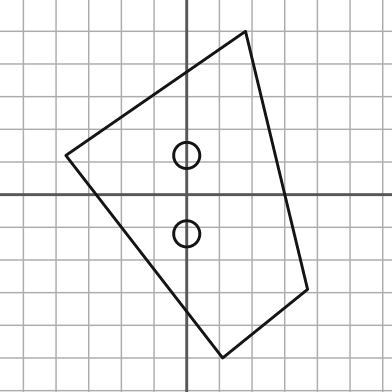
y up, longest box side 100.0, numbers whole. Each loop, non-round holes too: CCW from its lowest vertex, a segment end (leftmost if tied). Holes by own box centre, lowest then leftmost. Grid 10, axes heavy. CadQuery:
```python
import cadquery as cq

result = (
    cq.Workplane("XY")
    .moveTo(11.0, -50.0)
    .lineTo(37.0, -29.0)
    .lineTo(18.0, 50.0)
    .lineTo(-37.0, 12.0)
    .close()
    .moveTo(0.0, -12.0)
    .circle(4.0)
    .moveTo(0.0, 12.0)
    .circle(4.0)
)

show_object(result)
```